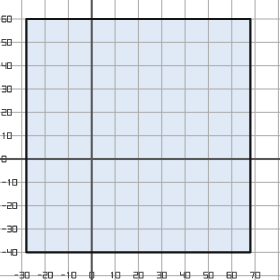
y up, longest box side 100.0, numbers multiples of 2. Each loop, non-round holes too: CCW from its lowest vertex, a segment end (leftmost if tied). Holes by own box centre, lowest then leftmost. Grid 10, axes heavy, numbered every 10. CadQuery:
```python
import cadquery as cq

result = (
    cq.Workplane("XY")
    .moveTo(-28.0, -40.0)
    .lineTo(68.0, -40.0)
    .lineTo(68.0, 60.0)
    .lineTo(-28.0, 60.0)
    .close()
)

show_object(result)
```